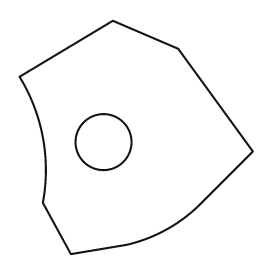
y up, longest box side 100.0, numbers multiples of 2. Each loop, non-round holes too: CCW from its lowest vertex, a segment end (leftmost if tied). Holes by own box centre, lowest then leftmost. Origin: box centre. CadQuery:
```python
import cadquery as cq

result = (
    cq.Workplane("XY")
    .moveTo(-28.0, -50.0)
    .lineTo(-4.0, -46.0)
    .threePointArc((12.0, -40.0), (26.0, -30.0))
    .lineTo(50.0, -6.0)
    .lineTo(18.0, 38.0)
    .lineTo(-10.0, 50.0)
    .lineTo(-50.0, 26.0)
    .threePointArc((-40.0, 0.0), (-40.0, -28.0))
    .close()
    .moveTo(-14.0, -2.0)
    .circle(12.0)
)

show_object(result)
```